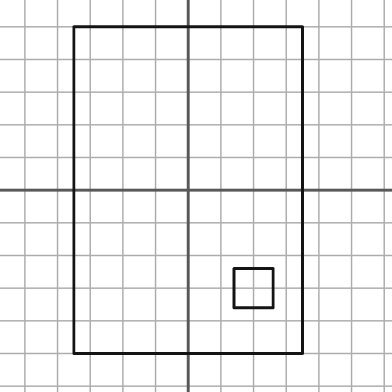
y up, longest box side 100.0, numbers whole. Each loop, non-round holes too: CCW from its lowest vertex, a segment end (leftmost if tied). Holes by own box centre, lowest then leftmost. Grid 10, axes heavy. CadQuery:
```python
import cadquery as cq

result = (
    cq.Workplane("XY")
    .moveTo(-35.0, -50.0)
    .lineTo(35.0, -50.0)
    .lineTo(35.0, 50.0)
    .lineTo(-35.0, 50.0)
    .close()
    .moveTo(14.0, -36.0)
    .lineTo(26.0, -36.0)
    .lineTo(26.0, -24.0)
    .lineTo(14.0, -24.0)
    .close()
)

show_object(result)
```